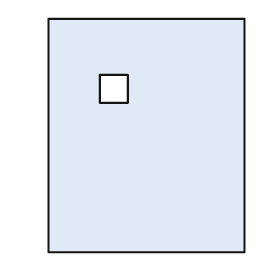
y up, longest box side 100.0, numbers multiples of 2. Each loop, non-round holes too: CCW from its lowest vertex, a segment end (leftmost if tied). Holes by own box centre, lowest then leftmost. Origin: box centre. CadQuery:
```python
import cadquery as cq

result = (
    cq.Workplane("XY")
    .moveTo(-42.0, -50.0)
    .lineTo(42.0, -50.0)
    .lineTo(42.0, 50.0)
    .lineTo(-42.0, 50.0)
    .close()
    .moveTo(-20.0, 14.0)
    .lineTo(-8.0, 14.0)
    .lineTo(-8.0, 26.0)
    .lineTo(-20.0, 26.0)
    .close()
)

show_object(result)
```